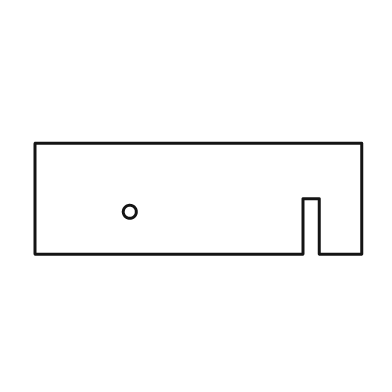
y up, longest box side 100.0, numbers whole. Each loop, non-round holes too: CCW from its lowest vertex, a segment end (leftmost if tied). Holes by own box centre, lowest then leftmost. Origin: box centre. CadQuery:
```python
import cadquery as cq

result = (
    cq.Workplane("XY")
    .moveTo(-50.0, -17.0)
    .lineTo(32.0, -17.0)
    .lineTo(32.0, 0.0)
    .lineTo(37.0, 0.0)
    .lineTo(37.0, -17.0)
    .lineTo(50.0, -17.0)
    .lineTo(50.0, 17.0)
    .lineTo(-50.0, 17.0)
    .close()
    .moveTo(-21.0, -4.0)
    .circle(2.0)
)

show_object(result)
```